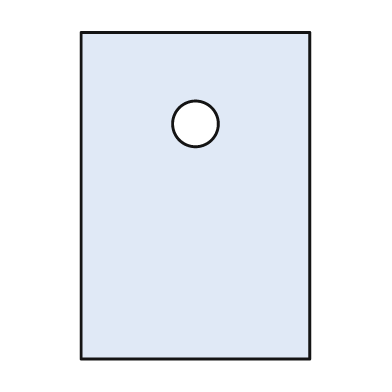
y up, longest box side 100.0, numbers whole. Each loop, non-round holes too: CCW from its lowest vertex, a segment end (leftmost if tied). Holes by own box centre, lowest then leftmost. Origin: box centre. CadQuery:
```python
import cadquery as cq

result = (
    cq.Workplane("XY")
    .moveTo(-35.0, -50.0)
    .lineTo(35.0, -50.0)
    .lineTo(35.0, 50.0)
    .lineTo(-35.0, 50.0)
    .close()
    .moveTo(0.0, 22.0)
    .circle(7.0)
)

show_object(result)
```